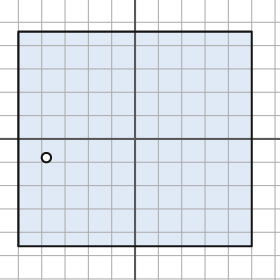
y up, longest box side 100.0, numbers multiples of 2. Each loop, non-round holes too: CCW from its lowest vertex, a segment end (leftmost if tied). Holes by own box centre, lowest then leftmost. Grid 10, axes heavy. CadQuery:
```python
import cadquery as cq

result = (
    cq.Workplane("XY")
    .moveTo(-50.0, -46.0)
    .lineTo(50.0, -46.0)
    .lineTo(50.0, 46.0)
    .lineTo(-50.0, 46.0)
    .close()
    .moveTo(-38.0, -8.0)
    .circle(2.0)
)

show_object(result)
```